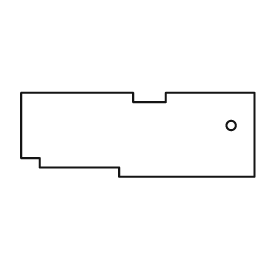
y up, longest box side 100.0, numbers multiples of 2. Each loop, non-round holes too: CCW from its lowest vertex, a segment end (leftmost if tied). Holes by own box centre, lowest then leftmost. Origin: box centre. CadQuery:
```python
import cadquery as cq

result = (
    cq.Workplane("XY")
    .moveTo(-8.0, -18.0)
    .lineTo(50.0, -18.0)
    .lineTo(50.0, 18.0)
    .lineTo(12.0, 18.0)
    .lineTo(12.0, 14.0)
    .lineTo(-2.0, 14.0)
    .lineTo(-2.0, 18.0)
    .lineTo(-50.0, 18.0)
    .lineTo(-50.0, -10.0)
    .lineTo(-42.0, -10.0)
    .lineTo(-42.0, -14.0)
    .lineTo(-8.0, -14.0)
    .close()
    .moveTo(40.0, 4.0)
    .circle(2.0)
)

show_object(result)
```